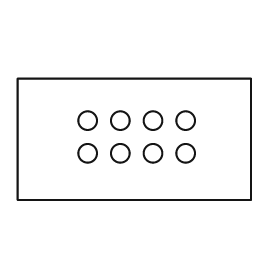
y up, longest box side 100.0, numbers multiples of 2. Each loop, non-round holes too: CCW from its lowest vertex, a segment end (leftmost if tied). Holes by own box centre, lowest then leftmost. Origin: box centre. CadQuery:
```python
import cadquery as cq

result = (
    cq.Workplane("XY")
    .moveTo(-50.0, -26.0)
    .lineTo(50.0, -26.0)
    .lineTo(50.0, 26.0)
    .lineTo(-50.0, 26.0)
    .close()
    .moveTo(-20.0, -6.0)
    .circle(4.0)
    .moveTo(-6.0, -6.0)
    .circle(4.0)
    .moveTo(8.0, -6.0)
    .circle(4.0)
    .moveTo(22.0, -6.0)
    .circle(4.0)
    .moveTo(-20.0, 8.0)
    .circle(4.0)
    .moveTo(-6.0, 8.0)
    .circle(4.0)
    .moveTo(8.0, 8.0)
    .circle(4.0)
    .moveTo(22.0, 8.0)
    .circle(4.0)
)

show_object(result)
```